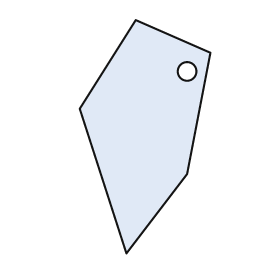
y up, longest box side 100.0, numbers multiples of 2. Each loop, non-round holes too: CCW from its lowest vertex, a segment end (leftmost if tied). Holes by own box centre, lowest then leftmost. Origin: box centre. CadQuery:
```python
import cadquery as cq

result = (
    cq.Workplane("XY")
    .moveTo(-8.0, -50.0)
    .lineTo(18.0, -16.0)
    .lineTo(28.0, 36.0)
    .lineTo(-4.0, 50.0)
    .lineTo(-28.0, 12.0)
    .close()
    .moveTo(18.0, 28.0)
    .circle(4.0)
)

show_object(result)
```